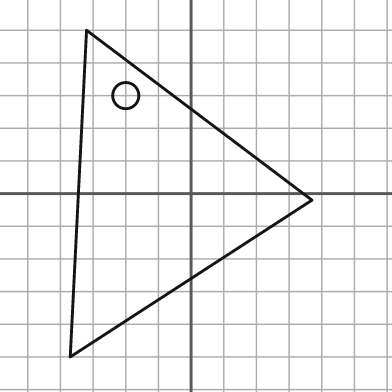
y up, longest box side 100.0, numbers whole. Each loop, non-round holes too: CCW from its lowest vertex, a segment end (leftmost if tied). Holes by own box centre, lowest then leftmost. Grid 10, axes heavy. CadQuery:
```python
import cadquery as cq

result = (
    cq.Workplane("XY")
    .moveTo(-37.0, -50.0)
    .lineTo(37.0, -2.0)
    .lineTo(-32.0, 50.0)
    .close()
    .moveTo(-20.0, 30.0)
    .circle(4.0)
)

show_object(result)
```